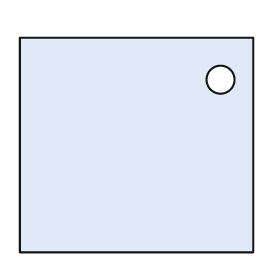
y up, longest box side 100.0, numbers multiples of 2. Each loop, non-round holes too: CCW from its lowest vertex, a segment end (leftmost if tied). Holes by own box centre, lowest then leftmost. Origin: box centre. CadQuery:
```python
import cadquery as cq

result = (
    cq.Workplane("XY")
    .moveTo(-50.0, -46.0)
    .lineTo(50.0, -46.0)
    .lineTo(50.0, 46.0)
    .lineTo(-50.0, 46.0)
    .close()
    .moveTo(36.0, 28.0)
    .circle(6.0)
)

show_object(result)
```